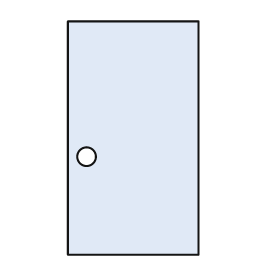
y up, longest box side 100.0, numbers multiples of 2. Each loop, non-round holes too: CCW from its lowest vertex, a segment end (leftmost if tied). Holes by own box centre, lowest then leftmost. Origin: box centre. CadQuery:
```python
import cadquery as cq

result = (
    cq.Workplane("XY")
    .moveTo(-28.0, -50.0)
    .lineTo(28.0, -50.0)
    .lineTo(28.0, 50.0)
    .lineTo(-28.0, 50.0)
    .close()
    .moveTo(-20.0, -8.0)
    .circle(4.0)
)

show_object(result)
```